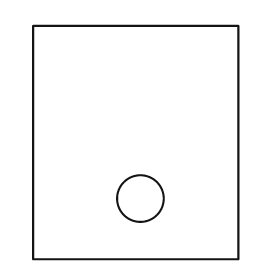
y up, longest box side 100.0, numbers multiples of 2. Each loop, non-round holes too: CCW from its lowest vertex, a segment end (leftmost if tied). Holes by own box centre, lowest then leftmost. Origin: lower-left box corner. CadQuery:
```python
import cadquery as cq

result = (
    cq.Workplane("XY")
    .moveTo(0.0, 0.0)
    .lineTo(88.0, 0.0)
    .lineTo(88.0, 100.0)
    .lineTo(0.0, 100.0)
    .close()
    .moveTo(46.0, 26.0)
    .circle(10.0)
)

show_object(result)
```